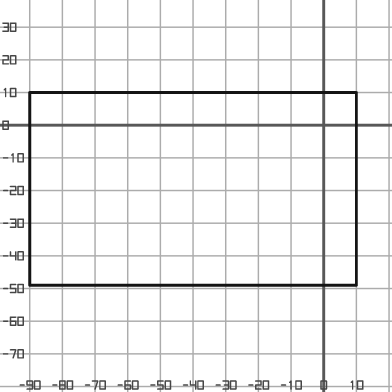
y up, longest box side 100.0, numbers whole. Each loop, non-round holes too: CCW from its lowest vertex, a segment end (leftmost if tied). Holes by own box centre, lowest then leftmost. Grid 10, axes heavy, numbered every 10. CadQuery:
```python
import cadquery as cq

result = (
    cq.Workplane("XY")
    .moveTo(-90.0, -49.0)
    .lineTo(10.0, -49.0)
    .lineTo(10.0, 10.0)
    .lineTo(-90.0, 10.0)
    .close()
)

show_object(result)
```